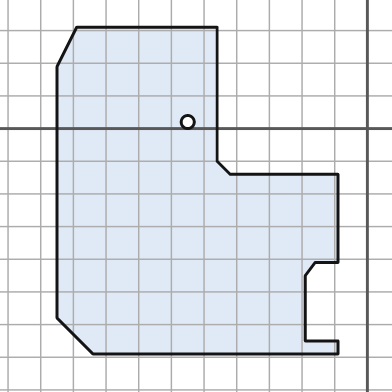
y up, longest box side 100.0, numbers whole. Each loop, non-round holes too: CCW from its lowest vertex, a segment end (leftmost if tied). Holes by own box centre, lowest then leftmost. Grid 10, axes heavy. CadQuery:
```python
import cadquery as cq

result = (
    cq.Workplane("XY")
    .moveTo(-84.0, -69.0)
    .lineTo(-9.0, -69.0)
    .lineTo(-9.0, -65.0)
    .lineTo(-19.0, -65.0)
    .lineTo(-19.0, -45.0)
    .lineTo(-16.0, -41.0)
    .lineTo(-9.0, -41.0)
    .lineTo(-9.0, -14.0)
    .lineTo(-42.0, -14.0)
    .lineTo(-46.0, -10.0)
    .lineTo(-46.0, 31.0)
    .lineTo(-89.0, 31.0)
    .lineTo(-95.0, 19.0)
    .lineTo(-95.0, -58.0)
    .close()
    .moveTo(-55.0, 2.0)
    .circle(2.0)
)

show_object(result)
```